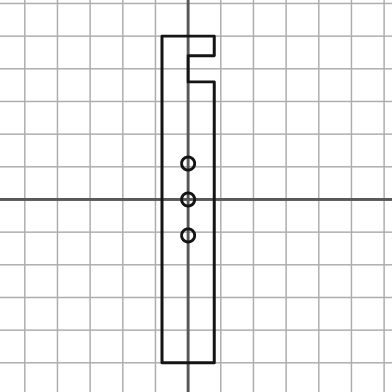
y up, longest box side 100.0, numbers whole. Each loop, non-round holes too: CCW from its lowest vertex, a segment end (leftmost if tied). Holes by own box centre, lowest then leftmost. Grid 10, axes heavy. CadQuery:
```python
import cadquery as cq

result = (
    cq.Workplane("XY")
    .moveTo(-8.0, -50.0)
    .lineTo(8.0, -50.0)
    .lineTo(8.0, 36.0)
    .lineTo(0.0, 36.0)
    .lineTo(0.0, 44.0)
    .lineTo(8.0, 44.0)
    .lineTo(8.0, 50.0)
    .lineTo(-8.0, 50.0)
    .close()
    .moveTo(0.0, -11.0)
    .circle(2.0)
    .moveTo(0.0, 0.0)
    .circle(2.0)
    .moveTo(0.0, 11.0)
    .circle(2.0)
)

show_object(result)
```